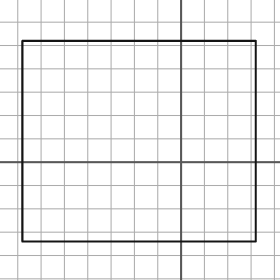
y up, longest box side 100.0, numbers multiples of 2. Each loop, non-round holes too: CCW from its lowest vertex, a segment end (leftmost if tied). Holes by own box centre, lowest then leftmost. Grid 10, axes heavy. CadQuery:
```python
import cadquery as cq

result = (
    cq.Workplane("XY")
    .moveTo(-68.0, -34.0)
    .lineTo(32.0, -34.0)
    .lineTo(32.0, 52.0)
    .lineTo(-68.0, 52.0)
    .close()
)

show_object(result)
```